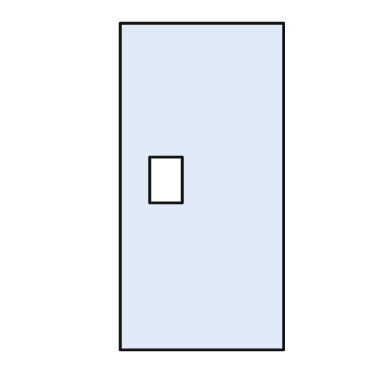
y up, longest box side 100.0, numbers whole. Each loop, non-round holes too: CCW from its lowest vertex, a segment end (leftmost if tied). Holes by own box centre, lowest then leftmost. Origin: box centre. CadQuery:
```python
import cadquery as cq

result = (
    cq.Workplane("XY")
    .moveTo(-25.0, -50.0)
    .lineTo(25.0, -50.0)
    .lineTo(25.0, 50.0)
    .lineTo(-25.0, 50.0)
    .close()
    .moveTo(-16.0, -5.0)
    .lineTo(-6.0, -5.0)
    .lineTo(-6.0, 9.0)
    .lineTo(-16.0, 9.0)
    .close()
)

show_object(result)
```